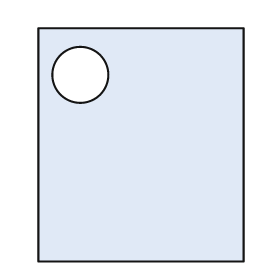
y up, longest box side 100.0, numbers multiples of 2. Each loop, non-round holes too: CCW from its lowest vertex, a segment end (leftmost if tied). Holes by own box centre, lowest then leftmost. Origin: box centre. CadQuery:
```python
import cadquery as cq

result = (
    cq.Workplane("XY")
    .moveTo(-44.0, -50.0)
    .lineTo(44.0, -50.0)
    .lineTo(44.0, 50.0)
    .lineTo(-44.0, 50.0)
    .close()
    .moveTo(-26.0, 30.0)
    .circle(12.0)
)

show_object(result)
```